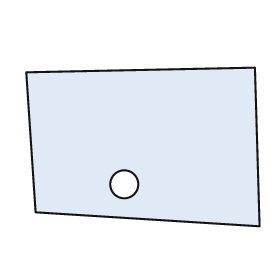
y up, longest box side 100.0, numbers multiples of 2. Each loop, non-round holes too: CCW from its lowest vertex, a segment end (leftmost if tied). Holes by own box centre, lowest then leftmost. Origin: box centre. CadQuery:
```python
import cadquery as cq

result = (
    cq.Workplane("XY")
    .moveTo(50.0, -34.0)
    .lineTo(48.0, 34.0)
    .lineTo(-50.0, 32.0)
    .lineTo(-46.0, -28.0)
    .close()
    .moveTo(-8.0, -16.0)
    .circle(6.0)
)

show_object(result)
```